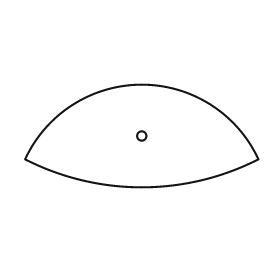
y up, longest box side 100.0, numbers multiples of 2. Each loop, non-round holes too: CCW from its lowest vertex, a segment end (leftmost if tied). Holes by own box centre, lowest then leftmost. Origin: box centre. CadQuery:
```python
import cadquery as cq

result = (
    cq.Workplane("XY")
    .moveTo(-50.0, -10.0)
    .threePointArc((0.0, -22.0), (50.0, -10.0))
    .threePointArc((0.0, 22.0), (-50.0, -10.0))
    .close()
    .moveTo(0.0, 0.0)
    .circle(2.0)
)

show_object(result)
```